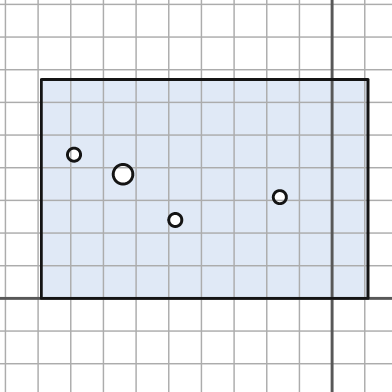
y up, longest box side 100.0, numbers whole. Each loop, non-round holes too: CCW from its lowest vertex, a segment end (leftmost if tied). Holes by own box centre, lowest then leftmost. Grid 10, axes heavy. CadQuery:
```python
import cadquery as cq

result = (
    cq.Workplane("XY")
    .moveTo(-89.0, 0.0)
    .lineTo(11.0, 0.0)
    .lineTo(11.0, 67.0)
    .lineTo(-89.0, 67.0)
    .close()
    .moveTo(-48.0, 24.0)
    .circle(2.0)
    .moveTo(-16.0, 31.0)
    .circle(2.0)
    .moveTo(-64.0, 38.0)
    .circle(3.0)
    .moveTo(-79.0, 44.0)
    .circle(2.0)
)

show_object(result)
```